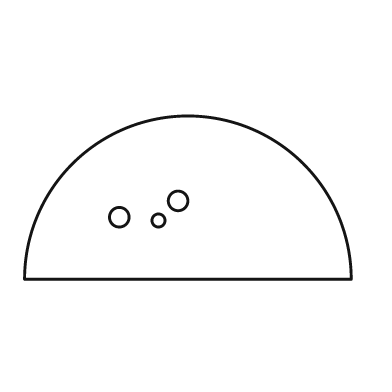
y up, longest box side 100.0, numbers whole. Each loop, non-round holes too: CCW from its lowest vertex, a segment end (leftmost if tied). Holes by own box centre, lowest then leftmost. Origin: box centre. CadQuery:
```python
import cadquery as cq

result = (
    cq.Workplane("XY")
    .moveTo(-50.0, -25.0)
    .lineTo(50.0, -25.0)
    .threePointArc((0.0, 25.0), (-50.0, -25.0))
    .close()
    .moveTo(-9.0, -7.0)
    .circle(2.0)
    .moveTo(-21.0, -6.0)
    .circle(3.0)
    .moveTo(-3.0, -1.0)
    .circle(3.0)
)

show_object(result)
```